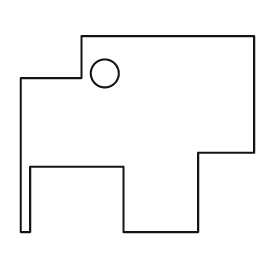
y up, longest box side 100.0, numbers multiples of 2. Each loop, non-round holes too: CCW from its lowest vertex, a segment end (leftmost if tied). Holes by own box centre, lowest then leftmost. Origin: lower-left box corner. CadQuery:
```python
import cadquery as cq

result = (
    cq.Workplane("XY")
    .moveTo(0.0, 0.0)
    .lineTo(4.0, 0.0)
    .lineTo(4.0, 28.0)
    .lineTo(44.0, 28.0)
    .lineTo(44.0, 0.0)
    .lineTo(76.0, 0.0)
    .lineTo(76.0, 34.0)
    .lineTo(100.0, 34.0)
    .lineTo(100.0, 84.0)
    .lineTo(26.0, 84.0)
    .lineTo(26.0, 66.0)
    .lineTo(0.0, 66.0)
    .close()
    .moveTo(36.0, 68.0)
    .circle(6.0)
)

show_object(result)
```